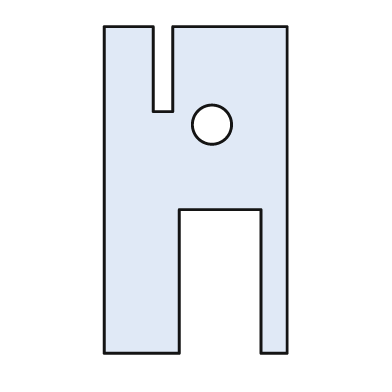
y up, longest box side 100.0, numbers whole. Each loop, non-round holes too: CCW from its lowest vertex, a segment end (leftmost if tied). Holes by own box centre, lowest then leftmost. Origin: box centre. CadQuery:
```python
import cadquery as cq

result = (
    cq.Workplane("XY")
    .moveTo(-28.0, -50.0)
    .lineTo(-5.0, -50.0)
    .lineTo(-5.0, -6.0)
    .lineTo(20.0, -6.0)
    .lineTo(20.0, -50.0)
    .lineTo(28.0, -50.0)
    .lineTo(28.0, 50.0)
    .lineTo(-7.0, 50.0)
    .lineTo(-7.0, 24.0)
    .lineTo(-13.0, 24.0)
    .lineTo(-13.0, 50.0)
    .lineTo(-28.0, 50.0)
    .close()
    .moveTo(5.0, 20.0)
    .circle(6.0)
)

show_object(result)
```